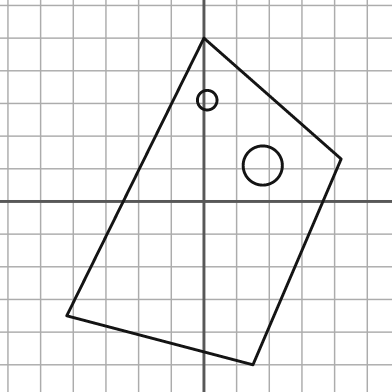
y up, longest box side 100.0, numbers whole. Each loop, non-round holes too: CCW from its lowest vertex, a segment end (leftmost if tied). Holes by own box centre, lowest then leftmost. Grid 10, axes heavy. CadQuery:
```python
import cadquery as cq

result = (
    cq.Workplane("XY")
    .moveTo(15.0, -50.0)
    .lineTo(42.0, 13.0)
    .lineTo(0.0, 50.0)
    .lineTo(-42.0, -35.0)
    .close()
    .moveTo(18.0, 11.0)
    .circle(6.0)
    .moveTo(1.0, 31.0)
    .circle(3.0)
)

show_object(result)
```